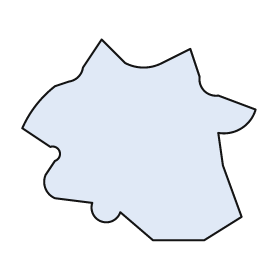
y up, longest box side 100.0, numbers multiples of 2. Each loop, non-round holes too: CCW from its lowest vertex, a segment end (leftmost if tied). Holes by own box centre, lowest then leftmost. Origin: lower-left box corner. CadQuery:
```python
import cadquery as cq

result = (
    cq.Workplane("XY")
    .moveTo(56.0, 0.0)
    .lineTo(78.0, 0.0)
    .lineTo(94.0, 10.0)
    .lineTo(86.0, 32.0)
    .lineTo(84.0, 46.0)
    .threePointArc((94.0, 48.0), (100.0, 56.0))
    .lineTo(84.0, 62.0)
    .threePointArc((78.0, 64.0), (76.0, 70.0))
    .lineTo(72.0, 82.0)
    .lineTo(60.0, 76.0)
    .threePointArc((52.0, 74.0), (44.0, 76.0))
    .lineTo(34.0, 86.0)
    .lineTo(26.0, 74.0)
    .threePointArc((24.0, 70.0), (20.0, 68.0))
    .lineTo(14.0, 66.0)
    .threePointArc((6.0, 58.0), (0.0, 48.0))
    .lineTo(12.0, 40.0)
    .threePointArc((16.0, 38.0), (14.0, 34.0))
    .lineTo(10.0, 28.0)
    .threePointArc((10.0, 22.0), (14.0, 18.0))
    .lineTo(30.0, 16.0)
    .threePointArc((34.0, 8.0), (42.0, 12.0))
    .close()
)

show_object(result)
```